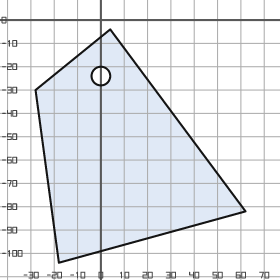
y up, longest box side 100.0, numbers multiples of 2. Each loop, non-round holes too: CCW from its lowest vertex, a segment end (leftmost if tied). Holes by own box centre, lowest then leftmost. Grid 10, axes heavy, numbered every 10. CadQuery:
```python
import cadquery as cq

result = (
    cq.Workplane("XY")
    .moveTo(-18.0, -104.0)
    .lineTo(62.0, -82.0)
    .lineTo(4.0, -4.0)
    .lineTo(-28.0, -30.0)
    .close()
    .moveTo(0.0, -24.0)
    .circle(4.0)
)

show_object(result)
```